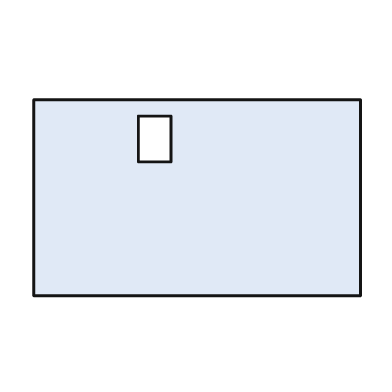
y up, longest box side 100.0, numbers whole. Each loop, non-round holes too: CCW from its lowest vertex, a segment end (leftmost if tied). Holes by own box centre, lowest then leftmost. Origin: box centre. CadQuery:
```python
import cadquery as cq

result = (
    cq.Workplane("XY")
    .moveTo(-50.0, -30.0)
    .lineTo(50.0, -30.0)
    .lineTo(50.0, 30.0)
    .lineTo(-50.0, 30.0)
    .close()
    .moveTo(-18.0, 11.0)
    .lineTo(-8.0, 11.0)
    .lineTo(-8.0, 25.0)
    .lineTo(-18.0, 25.0)
    .close()
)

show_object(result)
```